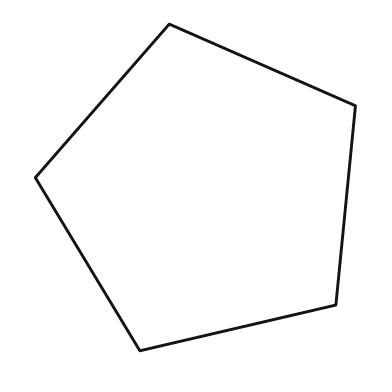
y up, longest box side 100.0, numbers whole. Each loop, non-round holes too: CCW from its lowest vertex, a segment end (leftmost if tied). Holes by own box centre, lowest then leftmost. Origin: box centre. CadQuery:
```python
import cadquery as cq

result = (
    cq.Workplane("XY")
    .moveTo(-17.0, -50.0)
    .lineTo(43.0, -36.0)
    .lineTo(49.0, 25.0)
    .lineTo(-8.0, 50.0)
    .lineTo(-49.0, 3.0)
    .close()
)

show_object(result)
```